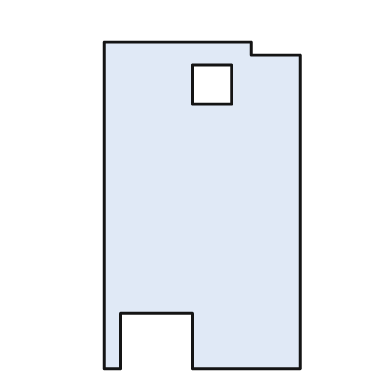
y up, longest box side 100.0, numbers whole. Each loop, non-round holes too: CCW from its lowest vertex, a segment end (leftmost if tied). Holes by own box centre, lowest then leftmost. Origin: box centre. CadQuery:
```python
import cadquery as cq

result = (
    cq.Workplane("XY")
    .moveTo(-30.0, -50.0)
    .lineTo(-25.0, -50.0)
    .lineTo(-25.0, -33.0)
    .lineTo(-3.0, -33.0)
    .lineTo(-3.0, -50.0)
    .lineTo(30.0, -50.0)
    .lineTo(30.0, 46.0)
    .lineTo(15.0, 46.0)
    .lineTo(15.0, 50.0)
    .lineTo(-30.0, 50.0)
    .close()
    .moveTo(-3.0, 31.0)
    .lineTo(9.0, 31.0)
    .lineTo(9.0, 43.0)
    .lineTo(-3.0, 43.0)
    .close()
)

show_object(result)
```